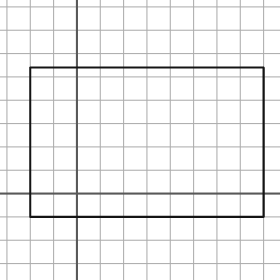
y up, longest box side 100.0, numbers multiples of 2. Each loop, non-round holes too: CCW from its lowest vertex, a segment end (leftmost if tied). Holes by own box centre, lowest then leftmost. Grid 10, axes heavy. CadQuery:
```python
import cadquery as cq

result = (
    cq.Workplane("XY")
    .moveTo(-20.0, -10.0)
    .lineTo(80.0, -10.0)
    .lineTo(80.0, 54.0)
    .lineTo(-20.0, 54.0)
    .close()
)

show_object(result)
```